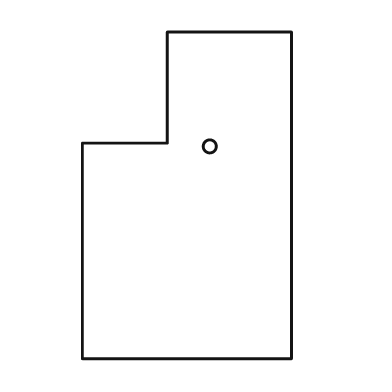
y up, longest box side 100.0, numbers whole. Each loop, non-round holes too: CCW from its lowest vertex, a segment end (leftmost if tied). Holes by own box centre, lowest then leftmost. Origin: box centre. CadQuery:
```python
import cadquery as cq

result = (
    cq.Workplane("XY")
    .moveTo(-32.0, -50.0)
    .lineTo(32.0, -50.0)
    .lineTo(32.0, 50.0)
    .lineTo(-6.0, 50.0)
    .lineTo(-6.0, 16.0)
    .lineTo(-32.0, 16.0)
    .close()
    .moveTo(7.0, 15.0)
    .circle(2.0)
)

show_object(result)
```